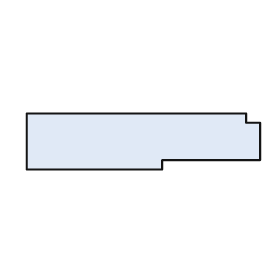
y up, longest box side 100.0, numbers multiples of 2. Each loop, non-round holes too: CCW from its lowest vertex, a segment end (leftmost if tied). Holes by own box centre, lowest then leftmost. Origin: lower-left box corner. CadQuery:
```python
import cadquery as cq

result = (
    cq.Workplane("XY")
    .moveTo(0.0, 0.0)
    .lineTo(58.0, 0.0)
    .lineTo(58.0, 4.0)
    .lineTo(100.0, 4.0)
    .lineTo(100.0, 20.0)
    .lineTo(94.0, 20.0)
    .lineTo(94.0, 24.0)
    .lineTo(0.0, 24.0)
    .close()
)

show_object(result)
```